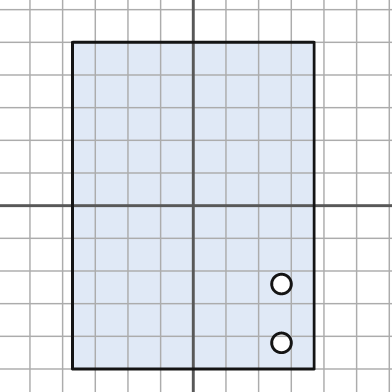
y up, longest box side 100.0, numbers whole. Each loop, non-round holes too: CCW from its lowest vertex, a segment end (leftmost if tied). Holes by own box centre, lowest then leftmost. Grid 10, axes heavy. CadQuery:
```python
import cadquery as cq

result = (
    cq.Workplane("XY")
    .moveTo(-37.0, -50.0)
    .lineTo(37.0, -50.0)
    .lineTo(37.0, 50.0)
    .lineTo(-37.0, 50.0)
    .close()
    .moveTo(27.0, -42.0)
    .circle(3.0)
    .moveTo(27.0, -24.0)
    .circle(3.0)
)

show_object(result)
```